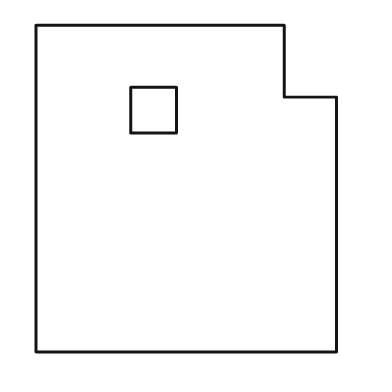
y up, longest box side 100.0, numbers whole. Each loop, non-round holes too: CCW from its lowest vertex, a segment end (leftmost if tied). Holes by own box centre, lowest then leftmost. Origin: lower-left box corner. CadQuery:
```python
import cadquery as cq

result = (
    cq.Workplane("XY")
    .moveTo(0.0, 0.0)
    .lineTo(92.0, 0.0)
    .lineTo(92.0, 78.0)
    .lineTo(76.0, 78.0)
    .lineTo(76.0, 100.0)
    .lineTo(0.0, 100.0)
    .close()
    .moveTo(29.0, 67.0)
    .lineTo(43.0, 67.0)
    .lineTo(43.0, 81.0)
    .lineTo(29.0, 81.0)
    .close()
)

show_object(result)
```